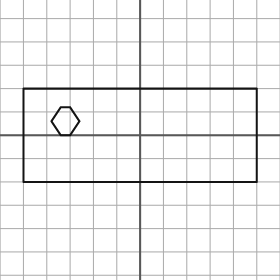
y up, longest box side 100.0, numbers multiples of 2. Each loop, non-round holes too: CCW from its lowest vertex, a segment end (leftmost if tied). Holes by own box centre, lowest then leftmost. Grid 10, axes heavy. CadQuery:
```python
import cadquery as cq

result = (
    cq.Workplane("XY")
    .moveTo(-50.0, -20.0)
    .lineTo(50.0, -20.0)
    .lineTo(50.0, 20.0)
    .lineTo(-50.0, 20.0)
    .close()
    .moveTo(-34.0, 0.0)
    .lineTo(-30.0, 0.0)
    .lineTo(-26.0, 6.0)
    .lineTo(-30.0, 12.0)
    .lineTo(-34.0, 12.0)
    .lineTo(-38.0, 6.0)
    .close()
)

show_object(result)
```